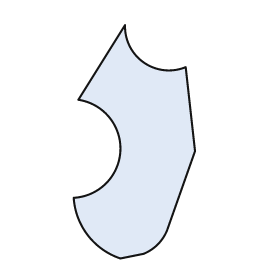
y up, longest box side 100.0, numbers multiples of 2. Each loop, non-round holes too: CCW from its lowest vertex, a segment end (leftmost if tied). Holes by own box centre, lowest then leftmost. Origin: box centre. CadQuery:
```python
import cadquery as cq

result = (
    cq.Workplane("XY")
    .moveTo(-6.0, -50.0)
    .lineTo(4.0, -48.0)
    .threePointArc((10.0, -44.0), (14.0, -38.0))
    .lineTo(26.0, -4.0)
    .lineTo(22.0, 32.0)
    .threePointArc((4.0, 34.0), (-4.0, 50.0))
    .lineTo(-24.0, 18.0)
    .threePointArc((-6.0, -4.0), (-26.0, -24.0))
    .threePointArc((-20.0, -40.0), (-6.0, -50.0))
    .close()
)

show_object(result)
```